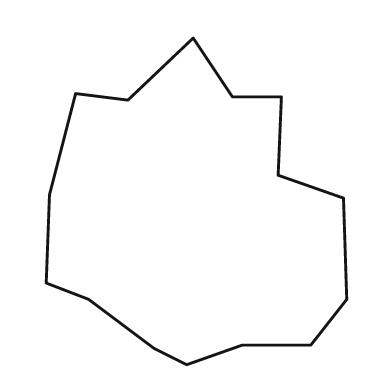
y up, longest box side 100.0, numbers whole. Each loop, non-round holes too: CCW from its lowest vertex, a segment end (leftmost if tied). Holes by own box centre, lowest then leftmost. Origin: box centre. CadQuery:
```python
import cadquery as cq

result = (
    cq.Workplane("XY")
    .moveTo(-3.0, -50.0)
    .lineTo(14.0, -44.0)
    .lineTo(35.0, -44.0)
    .lineTo(46.0, -30.0)
    .lineTo(45.0, 1.0)
    .lineTo(25.0, 8.0)
    .lineTo(26.0, 32.0)
    .lineTo(11.0, 32.0)
    .lineTo(-1.0, 50.0)
    .lineTo(-21.0, 31.0)
    .lineTo(-37.0, 33.0)
    .lineTo(-45.0, 2.0)
    .lineTo(-46.0, -25.0)
    .lineTo(-33.0, -30.0)
    .lineTo(-13.0, -45.0)
    .close()
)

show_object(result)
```